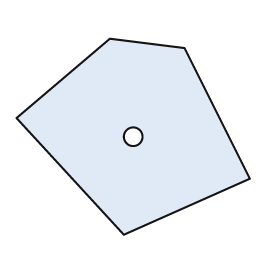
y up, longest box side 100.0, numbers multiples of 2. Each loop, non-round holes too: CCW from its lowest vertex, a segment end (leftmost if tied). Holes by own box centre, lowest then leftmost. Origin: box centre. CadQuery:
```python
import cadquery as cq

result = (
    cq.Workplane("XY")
    .moveTo(-4.0, -42.0)
    .lineTo(50.0, -18.0)
    .lineTo(22.0, 38.0)
    .lineTo(-10.0, 42.0)
    .lineTo(-50.0, 8.0)
    .close()
    .moveTo(0.0, 0.0)
    .circle(4.0)
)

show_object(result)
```